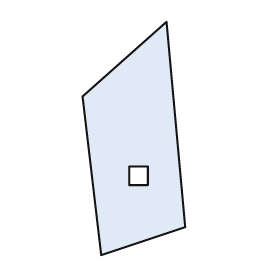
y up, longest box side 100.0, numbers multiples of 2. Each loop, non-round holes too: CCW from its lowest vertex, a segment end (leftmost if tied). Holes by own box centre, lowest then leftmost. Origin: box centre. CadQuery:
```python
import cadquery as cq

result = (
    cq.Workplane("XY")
    .moveTo(-14.0, -50.0)
    .lineTo(22.0, -38.0)
    .lineTo(14.0, 50.0)
    .lineTo(-22.0, 18.0)
    .close()
    .moveTo(-2.0, -20.0)
    .lineTo(6.0, -20.0)
    .lineTo(6.0, -12.0)
    .lineTo(-2.0, -12.0)
    .close()
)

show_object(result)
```